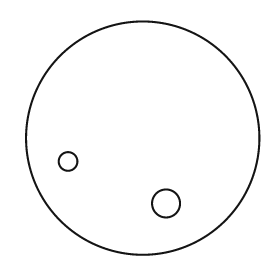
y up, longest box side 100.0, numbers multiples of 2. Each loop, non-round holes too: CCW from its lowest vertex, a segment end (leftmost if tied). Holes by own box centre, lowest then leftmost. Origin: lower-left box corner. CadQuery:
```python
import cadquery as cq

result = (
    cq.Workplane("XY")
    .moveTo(50.0, 50.0)
    .circle(50.0)
    .moveTo(60.0, 22.0)
    .circle(6.0)
    .moveTo(18.0, 40.0)
    .circle(4.0)
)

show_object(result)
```